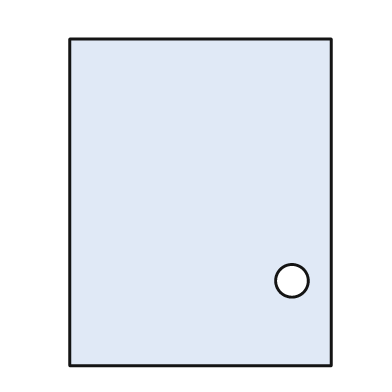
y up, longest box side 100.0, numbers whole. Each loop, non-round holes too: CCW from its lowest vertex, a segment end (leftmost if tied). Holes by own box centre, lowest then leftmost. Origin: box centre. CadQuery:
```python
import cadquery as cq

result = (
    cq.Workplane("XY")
    .moveTo(-40.0, -50.0)
    .lineTo(40.0, -50.0)
    .lineTo(40.0, 50.0)
    .lineTo(-40.0, 50.0)
    .close()
    .moveTo(28.0, -24.0)
    .circle(5.0)
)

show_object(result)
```